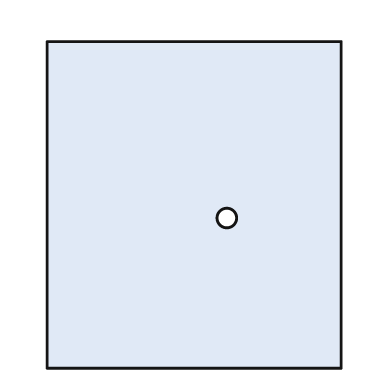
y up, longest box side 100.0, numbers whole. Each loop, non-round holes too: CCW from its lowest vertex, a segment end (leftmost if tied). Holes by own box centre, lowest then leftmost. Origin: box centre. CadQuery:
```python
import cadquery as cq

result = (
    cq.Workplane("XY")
    .moveTo(-45.0, -50.0)
    .lineTo(45.0, -50.0)
    .lineTo(45.0, 50.0)
    .lineTo(-45.0, 50.0)
    .close()
    .moveTo(10.0, -4.0)
    .circle(3.0)
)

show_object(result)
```